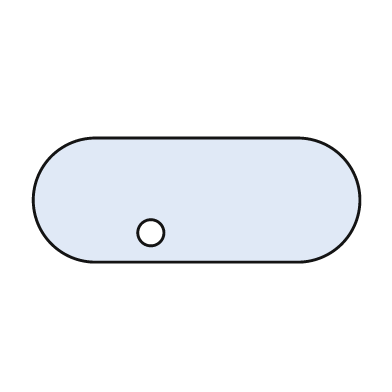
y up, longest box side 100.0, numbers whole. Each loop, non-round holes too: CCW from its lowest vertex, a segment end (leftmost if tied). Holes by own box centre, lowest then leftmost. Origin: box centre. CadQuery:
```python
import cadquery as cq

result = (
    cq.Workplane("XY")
    .moveTo(-31.0, -19.0)
    .lineTo(31.0, -19.0)
    .threePointArc((50.0, 0.0), (31.0, 19.0))
    .lineTo(-31.0, 19.0)
    .threePointArc((-50.0, 0.0), (-31.0, -19.0))
    .close()
    .moveTo(-14.0, -10.0)
    .circle(4.0)
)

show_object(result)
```